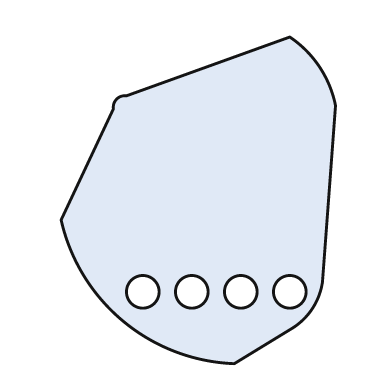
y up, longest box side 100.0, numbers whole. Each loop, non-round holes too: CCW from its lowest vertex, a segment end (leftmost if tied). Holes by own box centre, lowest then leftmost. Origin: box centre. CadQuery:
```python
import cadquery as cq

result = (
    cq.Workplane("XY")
    .moveTo(11.0, -50.0)
    .lineTo(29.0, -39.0)
    .threePointArc((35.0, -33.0), (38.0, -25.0))
    .lineTo(42.0, 29.0)
    .threePointArc((37.0, 41.0), (28.0, 50.0))
    .lineTo(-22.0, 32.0)
    .threePointArc((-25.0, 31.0), (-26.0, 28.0))
    .lineTo(-42.0, -6.0)
    .threePointArc((-23.0, -37.0), (11.0, -50.0))
    .close()
    .moveTo(-17.0, -28.0)
    .circle(5.0)
    .moveTo(-2.0, -28.0)
    .circle(5.0)
    .moveTo(13.0, -28.0)
    .circle(5.0)
    .moveTo(28.0, -28.0)
    .circle(5.0)
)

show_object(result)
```